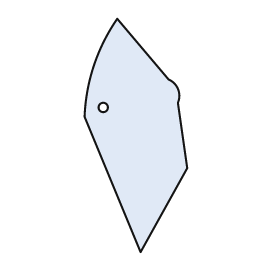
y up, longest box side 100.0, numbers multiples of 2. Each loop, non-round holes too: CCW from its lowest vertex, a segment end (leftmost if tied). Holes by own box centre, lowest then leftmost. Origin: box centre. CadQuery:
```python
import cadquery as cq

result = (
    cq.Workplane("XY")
    .moveTo(2.0, -50.0)
    .lineTo(22.0, -14.0)
    .lineTo(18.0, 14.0)
    .threePointArc((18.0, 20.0), (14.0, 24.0))
    .lineTo(-8.0, 50.0)
    .threePointArc((-18.0, 30.0), (-22.0, 8.0))
    .close()
    .moveTo(-14.0, 12.0)
    .circle(2.0)
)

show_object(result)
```